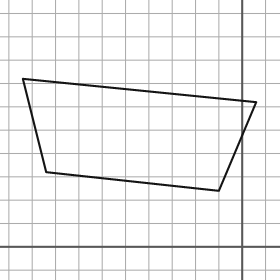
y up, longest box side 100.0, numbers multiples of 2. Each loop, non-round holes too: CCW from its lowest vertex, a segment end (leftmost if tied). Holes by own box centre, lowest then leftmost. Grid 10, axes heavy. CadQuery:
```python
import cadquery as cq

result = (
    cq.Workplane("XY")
    .moveTo(-10.0, 24.0)
    .lineTo(6.0, 62.0)
    .lineTo(-94.0, 72.0)
    .lineTo(-84.0, 32.0)
    .close()
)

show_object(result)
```